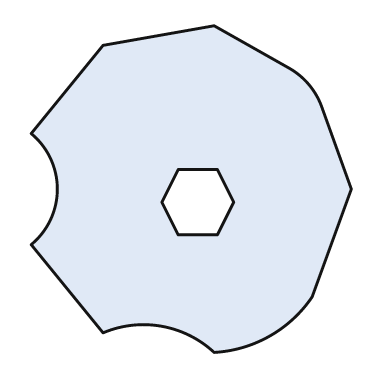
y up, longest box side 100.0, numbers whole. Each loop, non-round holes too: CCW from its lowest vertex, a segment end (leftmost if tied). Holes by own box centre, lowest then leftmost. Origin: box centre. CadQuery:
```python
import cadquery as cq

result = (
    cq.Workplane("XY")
    .moveTo(7.0, -50.0)
    .threePointArc((24.0, -45.0), (37.0, -33.0))
    .lineTo(49.0, 0.0)
    .lineTo(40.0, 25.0)
    .threePointArc((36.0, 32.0), (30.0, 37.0))
    .lineTo(7.0, 50.0)
    .lineTo(-27.0, 44.0)
    .lineTo(-49.0, 17.0)
    .threePointArc((-41.0, 0.0), (-49.0, -17.0))
    .lineTo(-27.0, -44.0)
    .threePointArc((-9.0, -42.0), (7.0, -50.0))
    .close()
    .moveTo(-4.0, -14.0)
    .lineTo(8.0, -14.0)
    .lineTo(13.0, -4.0)
    .lineTo(8.0, 6.0)
    .lineTo(-4.0, 6.0)
    .lineTo(-9.0, -4.0)
    .close()
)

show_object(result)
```